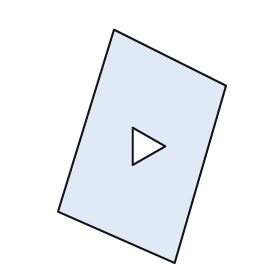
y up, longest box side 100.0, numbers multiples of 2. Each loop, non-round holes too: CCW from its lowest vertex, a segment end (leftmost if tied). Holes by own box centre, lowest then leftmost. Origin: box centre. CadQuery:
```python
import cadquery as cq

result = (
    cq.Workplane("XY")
    .moveTo(14.0, -50.0)
    .lineTo(36.0, 26.0)
    .lineTo(-12.0, 50.0)
    .lineTo(-36.0, -28.0)
    .close()
    .moveTo(-4.0, -8.0)
    .lineTo(10.0, 0.0)
    .lineTo(-4.0, 8.0)
    .close()
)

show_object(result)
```